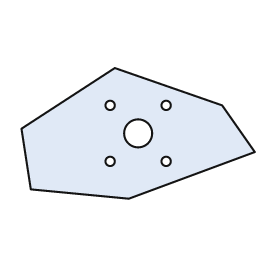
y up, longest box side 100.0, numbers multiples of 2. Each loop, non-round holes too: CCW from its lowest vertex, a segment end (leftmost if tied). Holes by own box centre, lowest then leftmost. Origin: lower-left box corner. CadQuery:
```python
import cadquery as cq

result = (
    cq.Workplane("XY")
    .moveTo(46.0, 0.0)
    .lineTo(100.0, 20.0)
    .lineTo(86.0, 40.0)
    .lineTo(40.0, 56.0)
    .lineTo(0.0, 30.0)
    .lineTo(4.0, 4.0)
    .close()
    .moveTo(38.0, 16.0)
    .circle(2.0)
    .moveTo(62.0, 16.0)
    .circle(2.0)
    .moveTo(50.0, 28.0)
    .circle(6.0)
    .moveTo(38.0, 40.0)
    .circle(2.0)
    .moveTo(62.0, 40.0)
    .circle(2.0)
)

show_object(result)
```